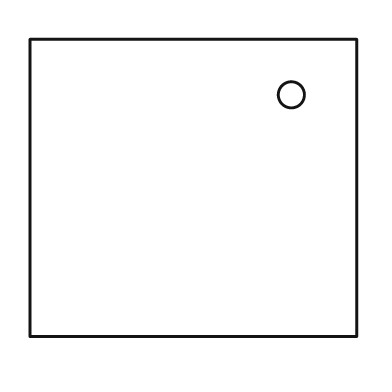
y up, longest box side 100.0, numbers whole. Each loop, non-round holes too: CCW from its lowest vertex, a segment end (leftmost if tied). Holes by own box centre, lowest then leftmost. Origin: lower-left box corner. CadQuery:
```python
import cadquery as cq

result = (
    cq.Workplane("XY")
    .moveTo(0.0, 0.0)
    .lineTo(100.0, 0.0)
    .lineTo(100.0, 91.0)
    .lineTo(0.0, 91.0)
    .close()
    .moveTo(80.0, 74.0)
    .circle(4.0)
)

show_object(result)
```